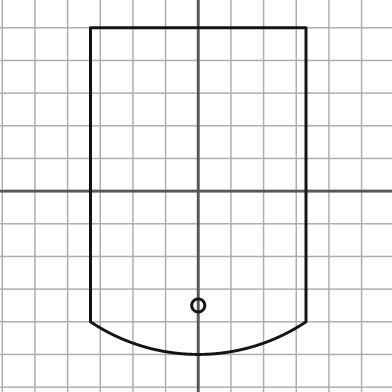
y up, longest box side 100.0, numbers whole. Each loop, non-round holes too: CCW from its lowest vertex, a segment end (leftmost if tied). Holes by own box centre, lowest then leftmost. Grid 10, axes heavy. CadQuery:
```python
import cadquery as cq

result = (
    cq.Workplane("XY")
    .moveTo(-33.0, -40.0)
    .threePointArc((0.0, -50.0), (33.0, -40.0))
    .lineTo(33.0, 50.0)
    .lineTo(-33.0, 50.0)
    .close()
    .moveTo(0.0, -35.0)
    .circle(2.0)
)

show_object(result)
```